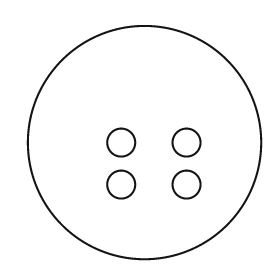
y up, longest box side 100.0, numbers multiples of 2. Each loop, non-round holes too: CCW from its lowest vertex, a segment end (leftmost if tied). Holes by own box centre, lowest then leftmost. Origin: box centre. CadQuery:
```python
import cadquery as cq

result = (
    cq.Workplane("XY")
    .moveTo(0.0, 0.0)
    .circle(50.0)
    .moveTo(-10.0, -18.0)
    .circle(6.0)
    .moveTo(18.0, -18.0)
    .circle(6.0)
    .moveTo(-10.0, 0.0)
    .circle(6.0)
    .moveTo(18.0, 0.0)
    .circle(6.0)
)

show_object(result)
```